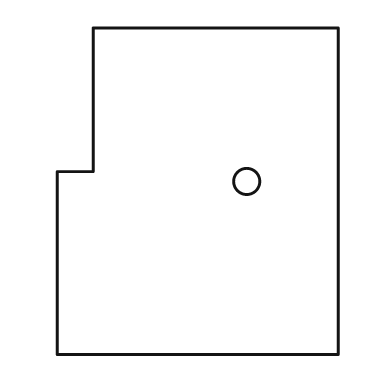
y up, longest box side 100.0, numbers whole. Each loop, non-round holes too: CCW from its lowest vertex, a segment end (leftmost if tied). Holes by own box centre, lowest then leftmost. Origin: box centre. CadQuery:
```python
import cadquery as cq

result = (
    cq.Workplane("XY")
    .moveTo(-43.0, -50.0)
    .lineTo(43.0, -50.0)
    .lineTo(43.0, 50.0)
    .lineTo(-32.0, 50.0)
    .lineTo(-32.0, 6.0)
    .lineTo(-43.0, 6.0)
    .close()
    .moveTo(15.0, 3.0)
    .circle(4.0)
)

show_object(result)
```